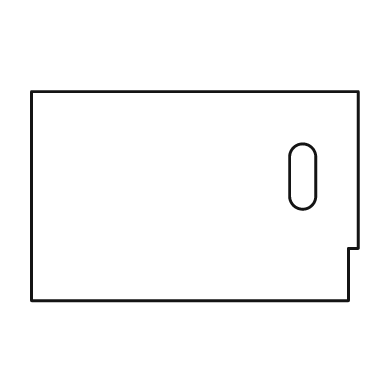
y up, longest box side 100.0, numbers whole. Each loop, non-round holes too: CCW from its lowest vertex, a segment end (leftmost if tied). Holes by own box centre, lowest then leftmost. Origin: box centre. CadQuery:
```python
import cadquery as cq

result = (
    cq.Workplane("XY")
    .moveTo(-50.0, -32.0)
    .lineTo(47.0, -32.0)
    .lineTo(47.0, -16.0)
    .lineTo(50.0, -16.0)
    .lineTo(50.0, 32.0)
    .lineTo(-50.0, 32.0)
    .close()
    .moveTo(29.0, 0.0)
    .threePointArc((33.0, -4.0), (37.0, 0.0))
    .lineTo(37.0, 12.0)
    .threePointArc((33.0, 16.0), (29.0, 12.0))
    .close()
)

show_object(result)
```